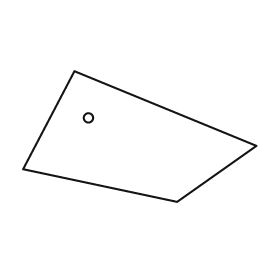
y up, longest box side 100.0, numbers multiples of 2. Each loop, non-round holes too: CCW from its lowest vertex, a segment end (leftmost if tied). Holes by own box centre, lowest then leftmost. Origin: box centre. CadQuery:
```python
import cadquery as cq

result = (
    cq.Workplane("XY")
    .moveTo(16.0, -28.0)
    .lineTo(50.0, -4.0)
    .lineTo(-28.0, 28.0)
    .lineTo(-50.0, -14.0)
    .close()
    .moveTo(-22.0, 8.0)
    .circle(2.0)
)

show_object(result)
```